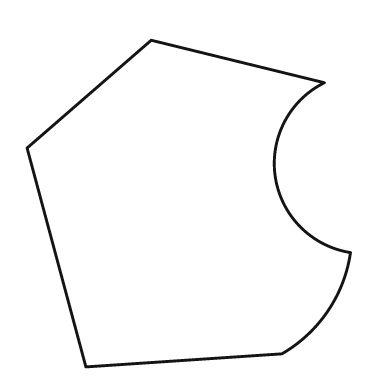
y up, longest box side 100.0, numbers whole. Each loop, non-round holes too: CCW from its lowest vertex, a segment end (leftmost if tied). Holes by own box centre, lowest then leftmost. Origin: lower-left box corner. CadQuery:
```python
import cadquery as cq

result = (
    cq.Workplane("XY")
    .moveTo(18.0, 0.0)
    .lineTo(78.0, 4.0)
    .threePointArc((92.0, 17.0), (99.0, 35.0))
    .threePointArc((76.0, 58.0), (91.0, 87.0))
    .lineTo(38.0, 100.0)
    .lineTo(0.0, 67.0)
    .close()
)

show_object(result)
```